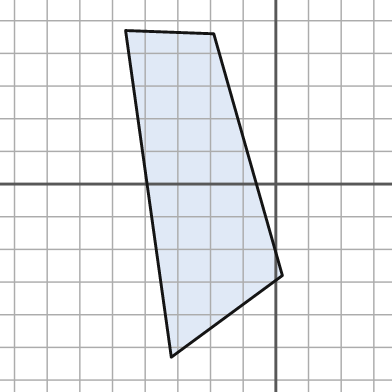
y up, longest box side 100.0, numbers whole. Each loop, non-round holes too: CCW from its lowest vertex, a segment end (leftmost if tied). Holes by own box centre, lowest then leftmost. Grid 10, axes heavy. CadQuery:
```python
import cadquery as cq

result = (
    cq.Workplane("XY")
    .moveTo(-32.0, -53.0)
    .lineTo(2.0, -28.0)
    .lineTo(-19.0, 46.0)
    .lineTo(-46.0, 47.0)
    .close()
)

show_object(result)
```